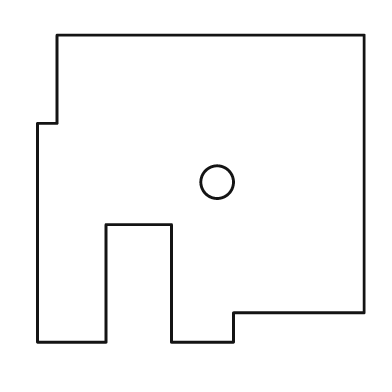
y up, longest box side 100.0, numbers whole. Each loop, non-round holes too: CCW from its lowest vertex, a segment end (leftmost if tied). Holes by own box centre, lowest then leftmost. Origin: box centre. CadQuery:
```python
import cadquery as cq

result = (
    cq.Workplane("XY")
    .moveTo(-50.0, -47.0)
    .lineTo(-29.0, -47.0)
    .lineTo(-29.0, -11.0)
    .lineTo(-9.0, -11.0)
    .lineTo(-9.0, -47.0)
    .lineTo(10.0, -47.0)
    .lineTo(10.0, -38.0)
    .lineTo(50.0, -38.0)
    .lineTo(50.0, 47.0)
    .lineTo(-44.0, 47.0)
    .lineTo(-44.0, 20.0)
    .lineTo(-50.0, 20.0)
    .close()
    .moveTo(5.0, 2.0)
    .circle(5.0)
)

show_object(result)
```